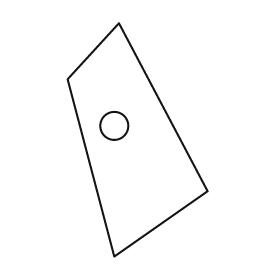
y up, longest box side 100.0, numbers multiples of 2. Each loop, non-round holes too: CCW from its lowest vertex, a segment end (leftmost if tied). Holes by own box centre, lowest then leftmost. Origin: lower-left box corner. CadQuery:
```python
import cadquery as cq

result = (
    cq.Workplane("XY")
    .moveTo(20.0, 0.0)
    .lineTo(60.0, 28.0)
    .lineTo(22.0, 100.0)
    .lineTo(0.0, 76.0)
    .close()
    .moveTo(20.0, 56.0)
    .circle(6.0)
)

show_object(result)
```